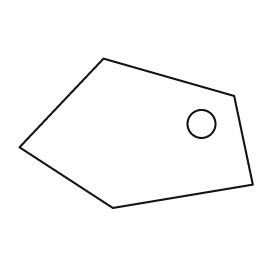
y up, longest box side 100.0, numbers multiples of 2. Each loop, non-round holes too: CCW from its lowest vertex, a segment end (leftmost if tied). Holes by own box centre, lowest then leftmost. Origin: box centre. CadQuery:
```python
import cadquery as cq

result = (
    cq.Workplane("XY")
    .moveTo(-10.0, -32.0)
    .lineTo(50.0, -22.0)
    .lineTo(42.0, 16.0)
    .lineTo(-14.0, 32.0)
    .lineTo(-50.0, -6.0)
    .close()
    .moveTo(28.0, 4.0)
    .circle(6.0)
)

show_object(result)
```